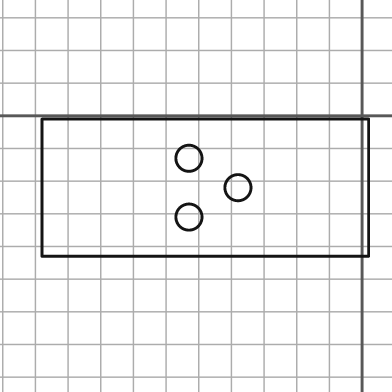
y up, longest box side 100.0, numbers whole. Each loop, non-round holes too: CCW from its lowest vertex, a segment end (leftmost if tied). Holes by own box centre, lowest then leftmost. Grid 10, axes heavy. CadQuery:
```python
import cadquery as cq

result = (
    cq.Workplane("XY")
    .moveTo(-98.0, -43.0)
    .lineTo(2.0, -43.0)
    .lineTo(2.0, -1.0)
    .lineTo(-98.0, -1.0)
    .close()
    .moveTo(-53.0, -31.0)
    .circle(4.0)
    .moveTo(-38.0, -22.0)
    .circle(4.0)
    .moveTo(-53.0, -13.0)
    .circle(4.0)
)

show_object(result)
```